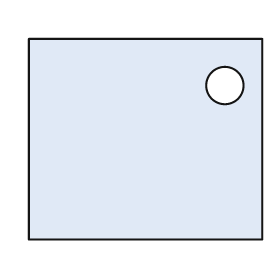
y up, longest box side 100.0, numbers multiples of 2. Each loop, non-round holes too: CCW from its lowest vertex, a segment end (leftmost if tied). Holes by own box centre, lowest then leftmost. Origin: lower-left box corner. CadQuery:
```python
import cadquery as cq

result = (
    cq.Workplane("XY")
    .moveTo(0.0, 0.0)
    .lineTo(100.0, 0.0)
    .lineTo(100.0, 86.0)
    .lineTo(0.0, 86.0)
    .close()
    .moveTo(84.0, 66.0)
    .circle(8.0)
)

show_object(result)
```